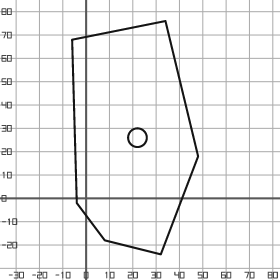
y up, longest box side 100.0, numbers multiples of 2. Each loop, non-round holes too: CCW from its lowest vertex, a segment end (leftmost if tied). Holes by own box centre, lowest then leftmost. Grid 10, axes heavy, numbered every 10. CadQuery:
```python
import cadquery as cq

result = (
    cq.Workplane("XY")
    .moveTo(32.0, -24.0)
    .lineTo(48.0, 18.0)
    .lineTo(34.0, 76.0)
    .lineTo(-6.0, 68.0)
    .lineTo(-4.0, -2.0)
    .lineTo(8.0, -18.0)
    .close()
    .moveTo(22.0, 26.0)
    .circle(4.0)
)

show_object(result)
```